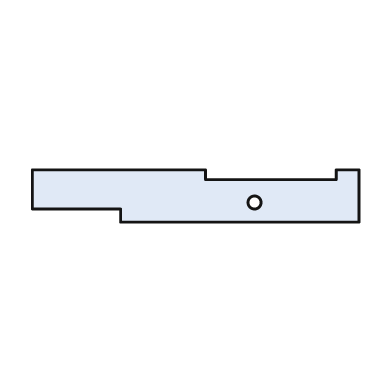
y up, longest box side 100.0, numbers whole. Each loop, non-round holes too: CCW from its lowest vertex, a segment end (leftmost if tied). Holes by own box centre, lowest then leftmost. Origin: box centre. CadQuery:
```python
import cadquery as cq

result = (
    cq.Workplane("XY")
    .moveTo(-23.0, -8.0)
    .lineTo(50.0, -8.0)
    .lineTo(50.0, 8.0)
    .lineTo(43.0, 8.0)
    .lineTo(43.0, 5.0)
    .lineTo(3.0, 5.0)
    .lineTo(3.0, 8.0)
    .lineTo(-50.0, 8.0)
    .lineTo(-50.0, -4.0)
    .lineTo(-23.0, -4.0)
    .close()
    .moveTo(18.0, -2.0)
    .circle(2.0)
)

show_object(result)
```